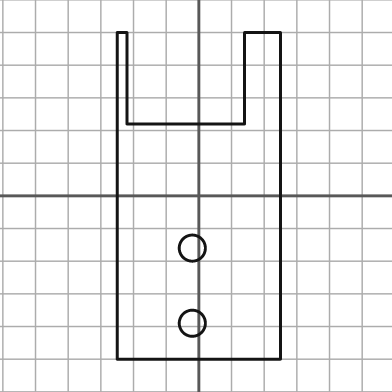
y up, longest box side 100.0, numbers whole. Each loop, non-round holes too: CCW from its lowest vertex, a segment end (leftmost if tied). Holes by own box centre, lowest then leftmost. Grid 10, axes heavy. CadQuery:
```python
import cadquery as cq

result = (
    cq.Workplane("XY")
    .moveTo(-25.0, -50.0)
    .lineTo(25.0, -50.0)
    .lineTo(25.0, 50.0)
    .lineTo(14.0, 50.0)
    .lineTo(14.0, 22.0)
    .lineTo(-22.0, 22.0)
    .lineTo(-22.0, 50.0)
    .lineTo(-25.0, 50.0)
    .close()
    .moveTo(-2.0, -39.0)
    .circle(4.0)
    .moveTo(-2.0, -16.0)
    .circle(4.0)
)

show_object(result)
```